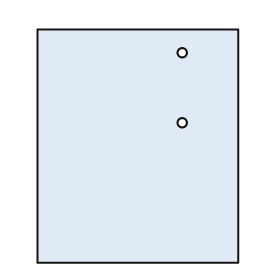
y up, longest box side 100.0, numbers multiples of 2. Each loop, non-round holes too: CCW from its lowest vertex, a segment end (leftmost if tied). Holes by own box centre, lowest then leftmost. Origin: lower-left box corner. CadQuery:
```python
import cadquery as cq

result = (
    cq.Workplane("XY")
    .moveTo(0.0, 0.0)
    .lineTo(86.0, 0.0)
    .lineTo(86.0, 100.0)
    .lineTo(0.0, 100.0)
    .close()
    .moveTo(62.0, 60.0)
    .circle(2.0)
    .moveTo(62.0, 90.0)
    .circle(2.0)
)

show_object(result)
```